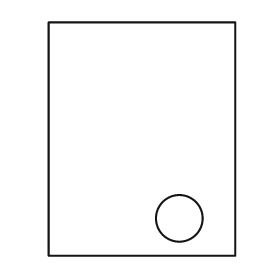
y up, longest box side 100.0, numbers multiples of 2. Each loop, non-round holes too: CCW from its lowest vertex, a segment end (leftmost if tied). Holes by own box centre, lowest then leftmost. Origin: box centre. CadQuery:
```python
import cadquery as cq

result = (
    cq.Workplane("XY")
    .moveTo(-40.0, -50.0)
    .lineTo(40.0, -50.0)
    .lineTo(40.0, 50.0)
    .lineTo(-40.0, 50.0)
    .close()
    .moveTo(16.0, -34.0)
    .circle(10.0)
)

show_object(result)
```